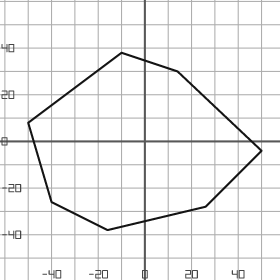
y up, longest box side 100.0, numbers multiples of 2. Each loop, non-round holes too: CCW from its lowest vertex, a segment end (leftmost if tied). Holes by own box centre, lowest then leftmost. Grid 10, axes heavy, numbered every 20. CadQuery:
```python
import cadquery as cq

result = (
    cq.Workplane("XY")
    .moveTo(-16.0, -38.0)
    .lineTo(26.0, -28.0)
    .lineTo(50.0, -4.0)
    .lineTo(14.0, 30.0)
    .lineTo(-10.0, 38.0)
    .lineTo(-50.0, 8.0)
    .lineTo(-40.0, -26.0)
    .close()
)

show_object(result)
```